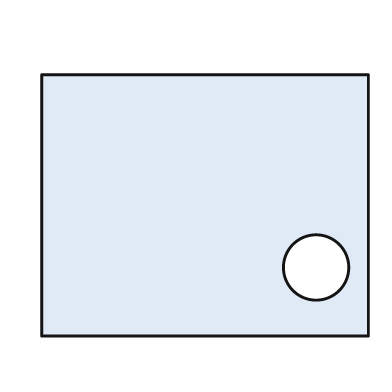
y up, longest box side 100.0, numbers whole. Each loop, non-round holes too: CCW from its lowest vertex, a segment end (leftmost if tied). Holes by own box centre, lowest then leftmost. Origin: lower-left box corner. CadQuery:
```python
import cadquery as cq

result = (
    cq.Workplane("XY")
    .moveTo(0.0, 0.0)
    .lineTo(100.0, 0.0)
    .lineTo(100.0, 80.0)
    .lineTo(0.0, 80.0)
    .close()
    .moveTo(84.0, 21.0)
    .circle(10.0)
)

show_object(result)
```